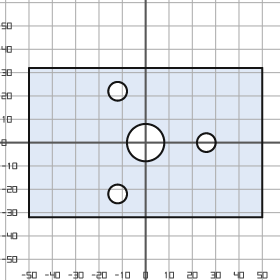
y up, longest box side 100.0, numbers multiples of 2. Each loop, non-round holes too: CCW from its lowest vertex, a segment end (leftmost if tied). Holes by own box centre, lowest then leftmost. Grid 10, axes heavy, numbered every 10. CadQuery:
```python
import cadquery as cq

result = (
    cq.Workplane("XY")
    .moveTo(-50.0, -32.0)
    .lineTo(50.0, -32.0)
    .lineTo(50.0, 32.0)
    .lineTo(-50.0, 32.0)
    .close()
    .moveTo(-12.0, -22.0)
    .circle(4.0)
    .moveTo(0.0, 0.0)
    .circle(8.0)
    .moveTo(26.0, 0.0)
    .circle(4.0)
    .moveTo(-12.0, 22.0)
    .circle(4.0)
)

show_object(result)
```